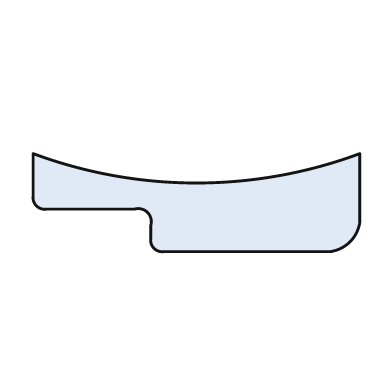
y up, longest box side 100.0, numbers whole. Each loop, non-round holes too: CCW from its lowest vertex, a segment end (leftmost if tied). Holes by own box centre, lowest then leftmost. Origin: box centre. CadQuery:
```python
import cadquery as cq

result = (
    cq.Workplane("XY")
    .moveTo(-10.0, -15.0)
    .lineTo(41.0, -15.0)
    .threePointArc((47.0, -12.0), (50.0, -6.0))
    .lineTo(50.0, 15.0)
    .threePointArc((0.0, 6.0), (-50.0, 15.0))
    .lineTo(-50.0, 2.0)
    .threePointArc((-49.0, -1.0), (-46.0, -2.0))
    .lineTo(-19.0, -2.0)
    .threePointArc((-15.0, -3.0), (-14.0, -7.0))
    .lineTo(-14.0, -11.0)
    .threePointArc((-13.0, -14.0), (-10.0, -15.0))
    .close()
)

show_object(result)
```